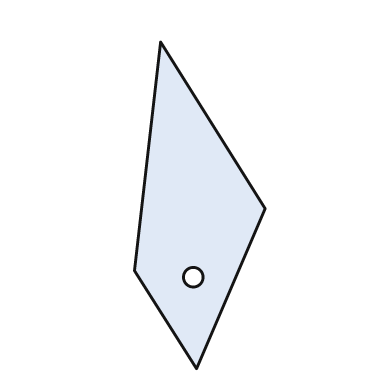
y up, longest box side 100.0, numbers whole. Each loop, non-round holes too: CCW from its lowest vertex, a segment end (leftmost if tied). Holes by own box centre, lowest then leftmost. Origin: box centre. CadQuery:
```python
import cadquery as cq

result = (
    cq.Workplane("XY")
    .moveTo(-1.0, -50.0)
    .lineTo(20.0, -1.0)
    .lineTo(-12.0, 50.0)
    .lineTo(-20.0, -20.0)
    .close()
    .moveTo(-2.0, -22.0)
    .circle(3.0)
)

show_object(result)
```